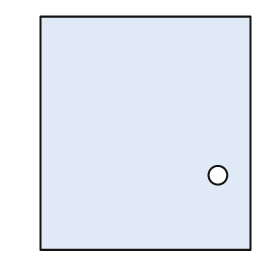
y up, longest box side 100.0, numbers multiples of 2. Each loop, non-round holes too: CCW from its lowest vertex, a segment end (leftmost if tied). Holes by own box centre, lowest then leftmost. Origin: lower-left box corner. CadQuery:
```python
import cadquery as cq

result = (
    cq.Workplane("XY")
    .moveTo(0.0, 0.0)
    .lineTo(90.0, 0.0)
    .lineTo(90.0, 100.0)
    .lineTo(0.0, 100.0)
    .close()
    .moveTo(76.0, 32.0)
    .circle(4.0)
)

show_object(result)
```